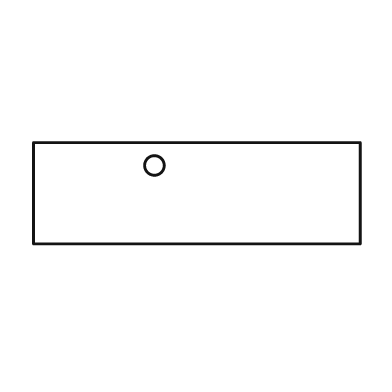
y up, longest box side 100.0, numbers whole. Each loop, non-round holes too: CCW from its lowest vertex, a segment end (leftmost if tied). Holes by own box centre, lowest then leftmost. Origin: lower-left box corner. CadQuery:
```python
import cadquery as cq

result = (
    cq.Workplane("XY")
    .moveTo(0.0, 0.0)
    .lineTo(100.0, 0.0)
    .lineTo(100.0, 31.0)
    .lineTo(0.0, 31.0)
    .close()
    .moveTo(37.0, 24.0)
    .circle(3.0)
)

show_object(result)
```